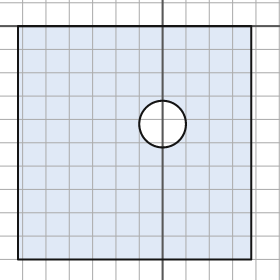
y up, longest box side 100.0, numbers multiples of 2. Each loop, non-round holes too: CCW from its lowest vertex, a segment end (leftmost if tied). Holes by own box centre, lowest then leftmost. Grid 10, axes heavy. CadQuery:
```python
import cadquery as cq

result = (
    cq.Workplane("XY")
    .moveTo(-62.0, -100.0)
    .lineTo(38.0, -100.0)
    .lineTo(38.0, 0.0)
    .lineTo(-62.0, 0.0)
    .close()
    .moveTo(0.0, -42.0)
    .circle(10.0)
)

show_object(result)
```